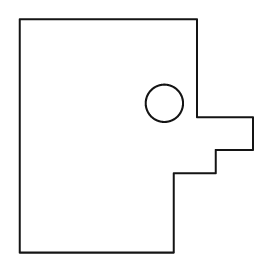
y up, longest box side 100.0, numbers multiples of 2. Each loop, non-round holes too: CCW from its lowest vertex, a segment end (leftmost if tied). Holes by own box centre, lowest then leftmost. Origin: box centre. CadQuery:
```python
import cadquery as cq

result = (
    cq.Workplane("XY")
    .moveTo(-50.0, -50.0)
    .lineTo(16.0, -50.0)
    .lineTo(16.0, -16.0)
    .lineTo(34.0, -16.0)
    .lineTo(34.0, -6.0)
    .lineTo(50.0, -6.0)
    .lineTo(50.0, 8.0)
    .lineTo(26.0, 8.0)
    .lineTo(26.0, 50.0)
    .lineTo(-50.0, 50.0)
    .close()
    .moveTo(12.0, 14.0)
    .circle(8.0)
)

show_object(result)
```